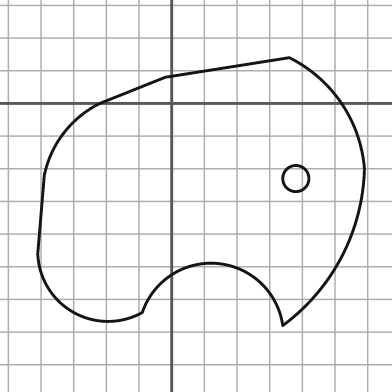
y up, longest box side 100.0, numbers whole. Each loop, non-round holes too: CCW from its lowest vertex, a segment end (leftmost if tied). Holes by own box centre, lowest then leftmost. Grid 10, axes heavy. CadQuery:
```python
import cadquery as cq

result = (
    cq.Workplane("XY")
    .moveTo(34.0, -68.0)
    .threePointArc((52.0, -47.0), (59.0, -20.0))
    .threePointArc((52.0, 0.0), (36.0, 14.0))
    .lineTo(-2.0, 8.0)
    .lineTo(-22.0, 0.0)
    .threePointArc((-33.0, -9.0), (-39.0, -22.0))
    .lineTo(-41.0, -46.0)
    .threePointArc((-30.0, -64.0), (-9.0, -64.0))
    .threePointArc((14.0, -49.0), (34.0, -68.0))
    .close()
    .moveTo(38.0, -23.0)
    .circle(4.0)
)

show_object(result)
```